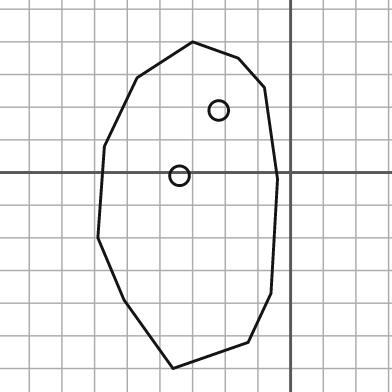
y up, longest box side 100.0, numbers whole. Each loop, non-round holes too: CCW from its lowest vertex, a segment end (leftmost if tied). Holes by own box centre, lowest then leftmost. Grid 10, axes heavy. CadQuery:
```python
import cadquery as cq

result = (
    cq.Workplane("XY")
    .moveTo(-36.0, -60.0)
    .lineTo(-13.0, -52.0)
    .lineTo(-6.0, -37.0)
    .lineTo(-4.0, -2.0)
    .lineTo(-8.0, 26.0)
    .lineTo(-16.0, 35.0)
    .lineTo(-30.0, 40.0)
    .lineTo(-47.0, 29.0)
    .lineTo(-57.0, 8.0)
    .lineTo(-59.0, -20.0)
    .lineTo(-51.0, -39.0)
    .close()
    .moveTo(-34.0, -1.0)
    .circle(3.0)
    .moveTo(-22.0, 19.0)
    .circle(3.0)
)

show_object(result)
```